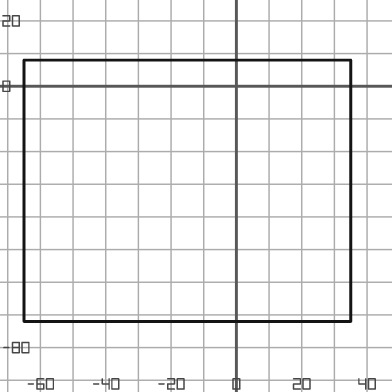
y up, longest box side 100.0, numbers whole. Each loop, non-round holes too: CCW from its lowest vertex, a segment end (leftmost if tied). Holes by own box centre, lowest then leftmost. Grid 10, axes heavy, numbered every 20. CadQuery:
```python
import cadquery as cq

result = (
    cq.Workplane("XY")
    .moveTo(-65.0, -72.0)
    .lineTo(35.0, -72.0)
    .lineTo(35.0, 8.0)
    .lineTo(-65.0, 8.0)
    .close()
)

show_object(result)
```